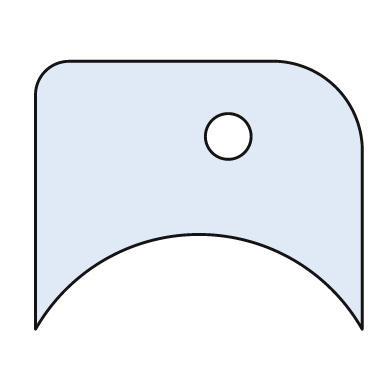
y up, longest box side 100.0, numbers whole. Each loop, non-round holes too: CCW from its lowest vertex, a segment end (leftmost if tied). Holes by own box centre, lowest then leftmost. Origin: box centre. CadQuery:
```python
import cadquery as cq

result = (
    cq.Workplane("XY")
    .moveTo(-50.0, -41.0)
    .threePointArc((0.0, -12.0), (50.0, -41.0))
    .lineTo(50.0, 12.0)
    .threePointArc((42.0, 33.0), (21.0, 41.0))
    .lineTo(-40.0, 41.0)
    .threePointArc((-47.0, 38.0), (-50.0, 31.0))
    .close()
    .moveTo(9.0, 18.0)
    .circle(7.0)
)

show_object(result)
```